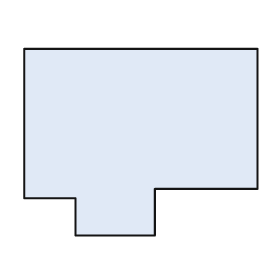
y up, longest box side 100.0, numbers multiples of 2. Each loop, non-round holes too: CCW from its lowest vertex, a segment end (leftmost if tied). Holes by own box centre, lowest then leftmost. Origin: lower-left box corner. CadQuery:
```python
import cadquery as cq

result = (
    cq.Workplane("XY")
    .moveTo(22.0, 0.0)
    .lineTo(56.0, 0.0)
    .lineTo(56.0, 20.0)
    .lineTo(100.0, 20.0)
    .lineTo(100.0, 80.0)
    .lineTo(0.0, 80.0)
    .lineTo(0.0, 16.0)
    .lineTo(22.0, 16.0)
    .close()
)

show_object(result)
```